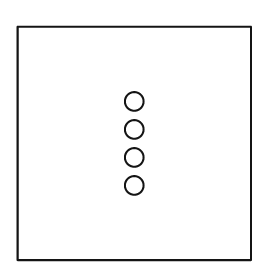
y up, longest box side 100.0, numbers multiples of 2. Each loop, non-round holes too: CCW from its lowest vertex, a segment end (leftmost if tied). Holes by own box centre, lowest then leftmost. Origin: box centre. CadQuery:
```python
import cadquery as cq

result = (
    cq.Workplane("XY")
    .moveTo(-50.0, -50.0)
    .lineTo(50.0, -50.0)
    .lineTo(50.0, 50.0)
    .lineTo(-50.0, 50.0)
    .close()
    .moveTo(0.0, -18.0)
    .circle(4.0)
    .moveTo(0.0, -6.0)
    .circle(4.0)
    .moveTo(0.0, 6.0)
    .circle(4.0)
    .moveTo(0.0, 18.0)
    .circle(4.0)
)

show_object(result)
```